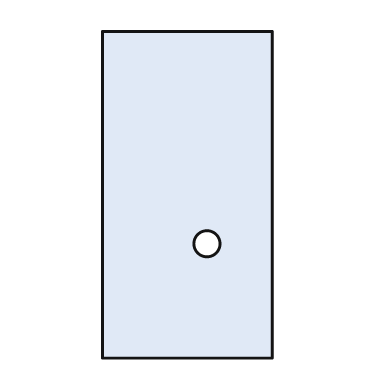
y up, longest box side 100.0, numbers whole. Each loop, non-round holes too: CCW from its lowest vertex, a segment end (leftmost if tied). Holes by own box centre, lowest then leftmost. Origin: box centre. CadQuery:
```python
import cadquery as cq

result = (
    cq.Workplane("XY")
    .moveTo(-26.0, -50.0)
    .lineTo(26.0, -50.0)
    .lineTo(26.0, 50.0)
    .lineTo(-26.0, 50.0)
    .close()
    .moveTo(6.0, -15.0)
    .circle(4.0)
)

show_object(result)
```